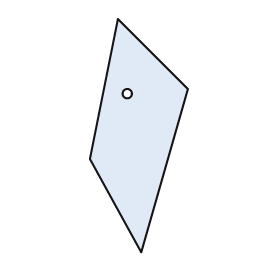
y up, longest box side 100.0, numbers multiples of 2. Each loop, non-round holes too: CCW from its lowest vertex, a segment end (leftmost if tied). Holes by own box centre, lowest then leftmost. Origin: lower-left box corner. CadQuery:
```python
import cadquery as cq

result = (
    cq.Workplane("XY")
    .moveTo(22.0, 0.0)
    .lineTo(42.0, 70.0)
    .lineTo(12.0, 100.0)
    .lineTo(0.0, 40.0)
    .close()
    .moveTo(16.0, 68.0)
    .circle(2.0)
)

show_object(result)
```